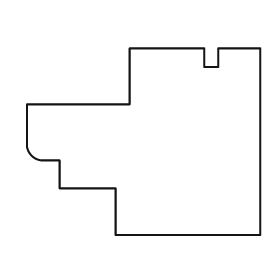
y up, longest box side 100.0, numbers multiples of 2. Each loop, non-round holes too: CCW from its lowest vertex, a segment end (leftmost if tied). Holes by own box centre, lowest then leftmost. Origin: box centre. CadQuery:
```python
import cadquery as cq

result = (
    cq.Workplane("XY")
    .moveTo(-12.0, -40.0)
    .lineTo(50.0, -40.0)
    .lineTo(50.0, 40.0)
    .lineTo(32.0, 40.0)
    .lineTo(32.0, 32.0)
    .lineTo(26.0, 32.0)
    .lineTo(26.0, 40.0)
    .lineTo(-6.0, 40.0)
    .lineTo(-6.0, 16.0)
    .lineTo(-50.0, 16.0)
    .lineTo(-50.0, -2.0)
    .threePointArc((-48.0, -6.0), (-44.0, -8.0))
    .lineTo(-36.0, -8.0)
    .lineTo(-36.0, -20.0)
    .lineTo(-12.0, -20.0)
    .close()
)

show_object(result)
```